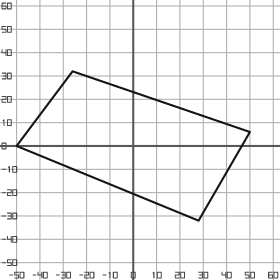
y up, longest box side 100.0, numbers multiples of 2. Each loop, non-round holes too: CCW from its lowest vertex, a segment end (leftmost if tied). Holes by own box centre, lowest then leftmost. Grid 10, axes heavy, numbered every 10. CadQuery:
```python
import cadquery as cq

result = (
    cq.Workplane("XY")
    .moveTo(28.0, -32.0)
    .lineTo(50.0, 6.0)
    .lineTo(-26.0, 32.0)
    .lineTo(-50.0, 0.0)
    .close()
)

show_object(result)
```